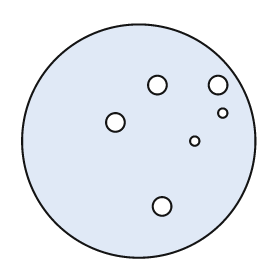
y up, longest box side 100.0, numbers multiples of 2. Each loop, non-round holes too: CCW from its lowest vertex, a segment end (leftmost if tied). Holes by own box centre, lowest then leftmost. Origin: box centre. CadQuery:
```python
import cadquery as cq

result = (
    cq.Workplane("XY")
    .moveTo(0.0, 0.0)
    .circle(50.0)
    .moveTo(10.0, -28.0)
    .circle(4.0)
    .moveTo(24.0, 0.0)
    .circle(2.0)
    .moveTo(-10.0, 8.0)
    .circle(4.0)
    .moveTo(36.0, 12.0)
    .circle(2.0)
    .moveTo(8.0, 24.0)
    .circle(4.0)
    .moveTo(34.0, 24.0)
    .circle(4.0)
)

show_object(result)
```